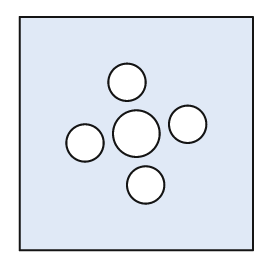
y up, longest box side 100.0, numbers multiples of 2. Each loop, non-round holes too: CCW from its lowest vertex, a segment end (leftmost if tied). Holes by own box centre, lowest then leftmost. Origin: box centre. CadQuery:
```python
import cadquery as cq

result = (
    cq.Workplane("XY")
    .moveTo(-50.0, -50.0)
    .lineTo(50.0, -50.0)
    .lineTo(50.0, 50.0)
    .lineTo(-50.0, 50.0)
    .close()
    .moveTo(4.0, -22.0)
    .circle(8.0)
    .moveTo(-22.0, -4.0)
    .circle(8.0)
    .moveTo(0.0, 0.0)
    .circle(10.0)
    .moveTo(22.0, 4.0)
    .circle(8.0)
    .moveTo(-4.0, 22.0)
    .circle(8.0)
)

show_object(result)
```